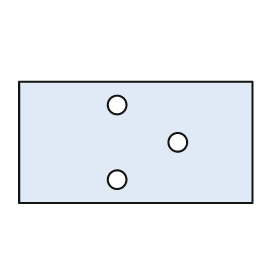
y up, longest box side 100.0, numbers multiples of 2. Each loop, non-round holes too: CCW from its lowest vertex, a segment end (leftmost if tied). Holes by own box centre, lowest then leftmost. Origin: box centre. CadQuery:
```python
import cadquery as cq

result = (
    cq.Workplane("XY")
    .moveTo(-50.0, -26.0)
    .lineTo(50.0, -26.0)
    .lineTo(50.0, 26.0)
    .lineTo(-50.0, 26.0)
    .close()
    .moveTo(-8.0, -16.0)
    .circle(4.0)
    .moveTo(18.0, 0.0)
    .circle(4.0)
    .moveTo(-8.0, 16.0)
    .circle(4.0)
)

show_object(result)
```